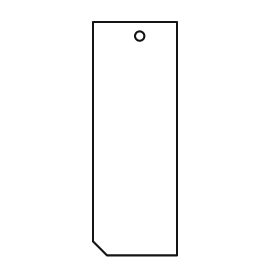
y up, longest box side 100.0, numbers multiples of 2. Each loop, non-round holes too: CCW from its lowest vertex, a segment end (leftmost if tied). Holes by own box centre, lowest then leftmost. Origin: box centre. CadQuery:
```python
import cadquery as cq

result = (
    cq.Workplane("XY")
    .moveTo(-12.0, -50.0)
    .lineTo(18.0, -50.0)
    .lineTo(18.0, 50.0)
    .lineTo(-18.0, 50.0)
    .lineTo(-18.0, -44.0)
    .close()
    .moveTo(2.0, 44.0)
    .circle(2.0)
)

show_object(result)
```